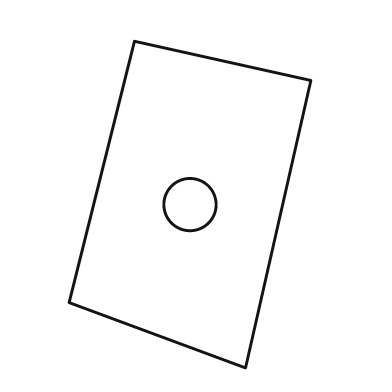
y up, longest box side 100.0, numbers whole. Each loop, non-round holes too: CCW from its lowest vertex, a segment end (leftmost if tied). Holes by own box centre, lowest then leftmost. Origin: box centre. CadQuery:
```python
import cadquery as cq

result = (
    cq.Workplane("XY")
    .moveTo(17.0, -50.0)
    .lineTo(37.0, 38.0)
    .lineTo(-17.0, 50.0)
    .lineTo(-37.0, -30.0)
    .close()
    .moveTo(0.0, 0.0)
    .circle(8.0)
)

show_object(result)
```